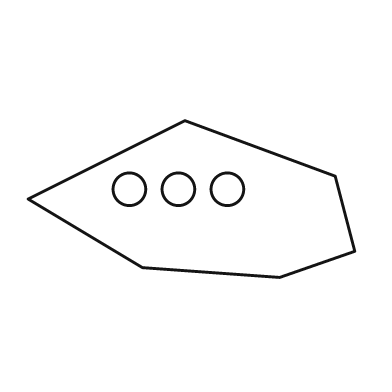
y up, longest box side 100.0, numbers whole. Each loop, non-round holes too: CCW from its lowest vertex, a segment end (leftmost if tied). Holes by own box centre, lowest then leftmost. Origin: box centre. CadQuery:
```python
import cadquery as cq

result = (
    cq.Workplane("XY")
    .moveTo(27.0, -24.0)
    .lineTo(50.0, -16.0)
    .lineTo(44.0, 7.0)
    .lineTo(-2.0, 24.0)
    .lineTo(-50.0, 0.0)
    .lineTo(-15.0, -21.0)
    .close()
    .moveTo(-19.0, 3.0)
    .circle(5.0)
    .moveTo(-4.0, 3.0)
    .circle(5.0)
    .moveTo(11.0, 3.0)
    .circle(5.0)
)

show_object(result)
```